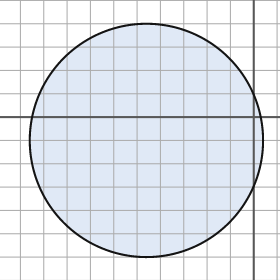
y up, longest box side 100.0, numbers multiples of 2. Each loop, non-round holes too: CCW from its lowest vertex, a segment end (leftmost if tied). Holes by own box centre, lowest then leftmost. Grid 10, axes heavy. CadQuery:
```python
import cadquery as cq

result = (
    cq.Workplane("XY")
    .moveTo(-46.0, -10.0)
    .circle(50.0)
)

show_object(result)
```